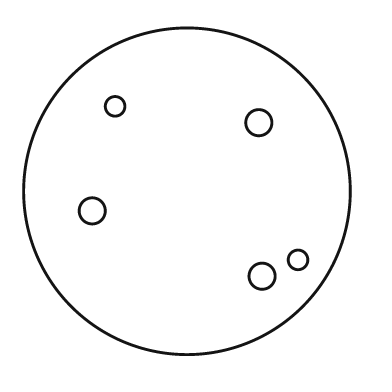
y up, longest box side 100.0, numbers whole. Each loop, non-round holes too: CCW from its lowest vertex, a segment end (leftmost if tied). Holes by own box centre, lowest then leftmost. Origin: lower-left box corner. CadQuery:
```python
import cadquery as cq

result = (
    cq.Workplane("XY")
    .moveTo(50.0, 50.0)
    .circle(50.0)
    .moveTo(73.0, 24.0)
    .circle(4.0)
    .moveTo(84.0, 29.0)
    .circle(3.0)
    .moveTo(21.0, 44.0)
    .circle(4.0)
    .moveTo(72.0, 71.0)
    .circle(4.0)
    .moveTo(28.0, 76.0)
    .circle(3.0)
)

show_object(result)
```